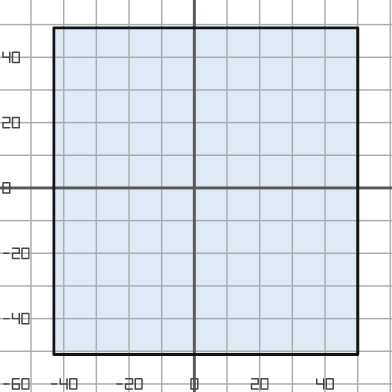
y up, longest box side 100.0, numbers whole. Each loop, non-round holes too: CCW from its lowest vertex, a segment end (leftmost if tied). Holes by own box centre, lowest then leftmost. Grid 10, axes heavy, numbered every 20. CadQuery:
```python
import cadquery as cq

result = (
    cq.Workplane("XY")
    .moveTo(-43.0, -51.0)
    .lineTo(50.0, -51.0)
    .lineTo(50.0, 49.0)
    .lineTo(-43.0, 49.0)
    .close()
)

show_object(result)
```